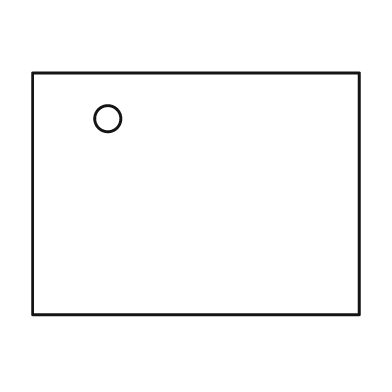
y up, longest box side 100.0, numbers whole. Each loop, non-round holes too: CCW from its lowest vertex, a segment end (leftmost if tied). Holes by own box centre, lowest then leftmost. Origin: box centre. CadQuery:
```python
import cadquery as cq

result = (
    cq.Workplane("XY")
    .moveTo(-50.0, -37.0)
    .lineTo(50.0, -37.0)
    .lineTo(50.0, 37.0)
    .lineTo(-50.0, 37.0)
    .close()
    .moveTo(-27.0, 23.0)
    .circle(4.0)
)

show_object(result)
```